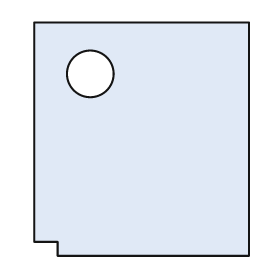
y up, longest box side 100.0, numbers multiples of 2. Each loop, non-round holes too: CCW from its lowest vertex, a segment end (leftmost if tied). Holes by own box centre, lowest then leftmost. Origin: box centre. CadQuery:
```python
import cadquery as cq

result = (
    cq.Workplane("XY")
    .moveTo(-36.0, -50.0)
    .lineTo(46.0, -50.0)
    .lineTo(46.0, 50.0)
    .lineTo(-46.0, 50.0)
    .lineTo(-46.0, -44.0)
    .lineTo(-36.0, -44.0)
    .close()
    .moveTo(-22.0, 28.0)
    .circle(10.0)
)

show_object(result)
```